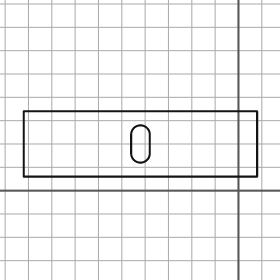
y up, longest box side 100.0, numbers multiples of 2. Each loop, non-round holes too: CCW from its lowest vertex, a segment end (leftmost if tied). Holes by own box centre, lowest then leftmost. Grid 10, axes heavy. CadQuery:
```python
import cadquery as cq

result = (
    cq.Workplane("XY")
    .moveTo(-92.0, 6.0)
    .lineTo(8.0, 6.0)
    .lineTo(8.0, 34.0)
    .lineTo(-92.0, 34.0)
    .close()
    .moveTo(-46.0, 16.0)
    .threePointArc((-42.0, 12.0), (-38.0, 16.0))
    .lineTo(-38.0, 24.0)
    .threePointArc((-42.0, 28.0), (-46.0, 24.0))
    .close()
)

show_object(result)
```